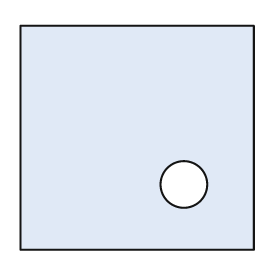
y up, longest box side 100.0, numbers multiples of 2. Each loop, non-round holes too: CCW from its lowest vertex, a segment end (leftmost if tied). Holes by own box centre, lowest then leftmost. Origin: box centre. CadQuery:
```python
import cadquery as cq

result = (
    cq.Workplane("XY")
    .moveTo(-50.0, -48.0)
    .lineTo(50.0, -48.0)
    .lineTo(50.0, 48.0)
    .lineTo(-50.0, 48.0)
    .close()
    .moveTo(20.0, -20.0)
    .circle(10.0)
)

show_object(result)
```